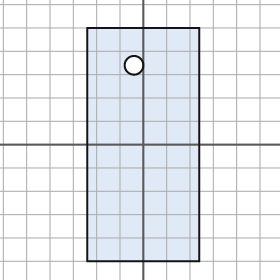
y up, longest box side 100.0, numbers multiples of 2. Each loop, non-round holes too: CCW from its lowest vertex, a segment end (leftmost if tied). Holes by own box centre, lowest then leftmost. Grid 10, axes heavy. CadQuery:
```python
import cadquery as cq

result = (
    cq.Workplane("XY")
    .moveTo(-24.0, -50.0)
    .lineTo(24.0, -50.0)
    .lineTo(24.0, 50.0)
    .lineTo(-24.0, 50.0)
    .close()
    .moveTo(-4.0, 34.0)
    .circle(4.0)
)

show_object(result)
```